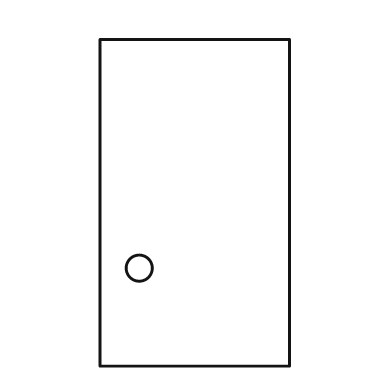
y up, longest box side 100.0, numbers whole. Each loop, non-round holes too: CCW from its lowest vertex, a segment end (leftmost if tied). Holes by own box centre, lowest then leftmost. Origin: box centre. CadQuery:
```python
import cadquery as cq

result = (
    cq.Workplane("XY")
    .moveTo(-29.0, -50.0)
    .lineTo(29.0, -50.0)
    .lineTo(29.0, 50.0)
    .lineTo(-29.0, 50.0)
    .close()
    .moveTo(-17.0, -20.0)
    .circle(4.0)
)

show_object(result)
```